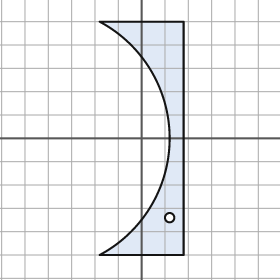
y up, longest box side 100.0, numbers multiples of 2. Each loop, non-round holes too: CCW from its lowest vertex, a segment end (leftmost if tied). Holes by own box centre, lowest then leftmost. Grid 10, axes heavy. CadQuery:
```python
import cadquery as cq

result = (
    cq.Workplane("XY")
    .moveTo(-18.0, -50.0)
    .lineTo(18.0, -50.0)
    .lineTo(18.0, 50.0)
    .lineTo(-18.0, 50.0)
    .threePointArc((12.0, 0.0), (-18.0, -50.0))
    .close()
    .moveTo(12.0, -34.0)
    .circle(2.0)
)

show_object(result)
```